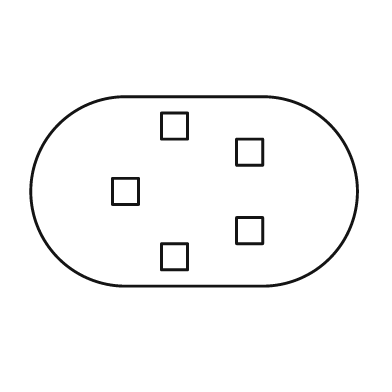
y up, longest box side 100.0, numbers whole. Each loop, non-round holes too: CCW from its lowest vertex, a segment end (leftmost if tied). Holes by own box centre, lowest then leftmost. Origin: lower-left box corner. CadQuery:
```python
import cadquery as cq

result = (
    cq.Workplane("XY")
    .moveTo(29.0, 0.0)
    .lineTo(71.0, 0.0)
    .threePointArc((100.0, 29.0), (71.0, 58.0))
    .lineTo(29.0, 58.0)
    .threePointArc((0.0, 29.0), (29.0, 0.0))
    .close()
    .moveTo(40.0, 5.0)
    .lineTo(48.0, 5.0)
    .lineTo(48.0, 13.0)
    .lineTo(40.0, 13.0)
    .close()
    .moveTo(63.0, 13.0)
    .lineTo(71.0, 13.0)
    .lineTo(71.0, 21.0)
    .lineTo(63.0, 21.0)
    .close()
    .moveTo(25.0, 25.0)
    .lineTo(33.0, 25.0)
    .lineTo(33.0, 33.0)
    .lineTo(25.0, 33.0)
    .close()
    .moveTo(63.0, 37.0)
    .lineTo(71.0, 37.0)
    .lineTo(71.0, 45.0)
    .lineTo(63.0, 45.0)
    .close()
    .moveTo(40.0, 45.0)
    .lineTo(48.0, 45.0)
    .lineTo(48.0, 53.0)
    .lineTo(40.0, 53.0)
    .close()
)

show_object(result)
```